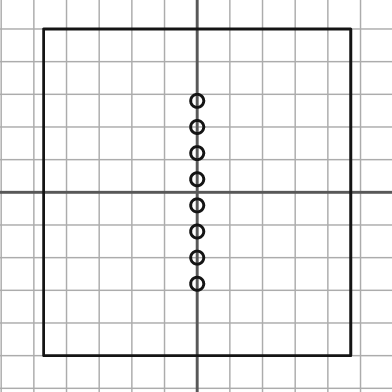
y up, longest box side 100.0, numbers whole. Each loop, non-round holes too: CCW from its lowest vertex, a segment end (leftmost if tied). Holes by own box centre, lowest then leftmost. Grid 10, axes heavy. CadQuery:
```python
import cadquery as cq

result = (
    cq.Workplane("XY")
    .moveTo(-47.0, -50.0)
    .lineTo(47.0, -50.0)
    .lineTo(47.0, 50.0)
    .lineTo(-47.0, 50.0)
    .close()
    .moveTo(0.0, -28.0)
    .circle(2.0)
    .moveTo(0.0, -20.0)
    .circle(2.0)
    .moveTo(0.0, -12.0)
    .circle(2.0)
    .moveTo(0.0, -4.0)
    .circle(2.0)
    .moveTo(0.0, 4.0)
    .circle(2.0)
    .moveTo(0.0, 12.0)
    .circle(2.0)
    .moveTo(0.0, 20.0)
    .circle(2.0)
    .moveTo(0.0, 28.0)
    .circle(2.0)
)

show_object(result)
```